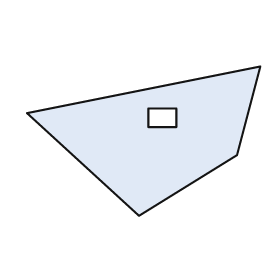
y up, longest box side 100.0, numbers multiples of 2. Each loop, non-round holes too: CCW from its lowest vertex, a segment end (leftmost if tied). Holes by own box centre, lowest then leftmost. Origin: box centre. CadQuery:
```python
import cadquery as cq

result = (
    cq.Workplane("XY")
    .moveTo(-2.0, -32.0)
    .lineTo(40.0, -6.0)
    .lineTo(50.0, 32.0)
    .lineTo(-50.0, 12.0)
    .close()
    .moveTo(2.0, 6.0)
    .lineTo(14.0, 6.0)
    .lineTo(14.0, 14.0)
    .lineTo(2.0, 14.0)
    .close()
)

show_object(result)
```